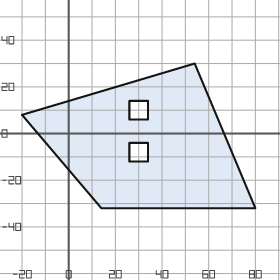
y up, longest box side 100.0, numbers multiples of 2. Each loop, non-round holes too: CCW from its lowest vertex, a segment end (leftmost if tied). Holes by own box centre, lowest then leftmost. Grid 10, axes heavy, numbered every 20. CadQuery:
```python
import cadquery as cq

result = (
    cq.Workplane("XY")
    .moveTo(14.0, -32.0)
    .lineTo(80.0, -32.0)
    .lineTo(54.0, 30.0)
    .lineTo(-20.0, 8.0)
    .close()
    .moveTo(26.0, -12.0)
    .lineTo(34.0, -12.0)
    .lineTo(34.0, -4.0)
    .lineTo(26.0, -4.0)
    .close()
    .moveTo(26.0, 6.0)
    .lineTo(34.0, 6.0)
    .lineTo(34.0, 14.0)
    .lineTo(26.0, 14.0)
    .close()
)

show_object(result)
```